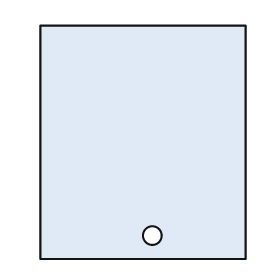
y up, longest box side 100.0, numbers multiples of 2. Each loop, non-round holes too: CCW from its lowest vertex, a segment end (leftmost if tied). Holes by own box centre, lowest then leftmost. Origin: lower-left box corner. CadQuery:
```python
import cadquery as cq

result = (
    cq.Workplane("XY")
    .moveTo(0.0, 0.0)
    .lineTo(88.0, 0.0)
    .lineTo(88.0, 100.0)
    .lineTo(0.0, 100.0)
    .close()
    .moveTo(48.0, 10.0)
    .circle(4.0)
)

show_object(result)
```